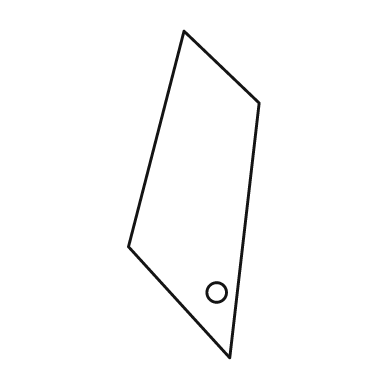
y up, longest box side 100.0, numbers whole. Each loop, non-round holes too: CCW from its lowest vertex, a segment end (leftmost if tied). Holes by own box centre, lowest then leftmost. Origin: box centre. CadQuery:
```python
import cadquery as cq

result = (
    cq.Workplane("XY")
    .moveTo(11.0, -50.0)
    .lineTo(20.0, 28.0)
    .lineTo(-3.0, 50.0)
    .lineTo(-20.0, -16.0)
    .close()
    .moveTo(7.0, -30.0)
    .circle(3.0)
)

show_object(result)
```